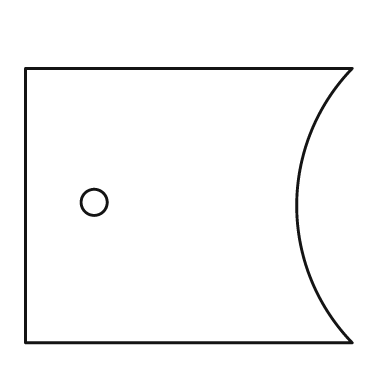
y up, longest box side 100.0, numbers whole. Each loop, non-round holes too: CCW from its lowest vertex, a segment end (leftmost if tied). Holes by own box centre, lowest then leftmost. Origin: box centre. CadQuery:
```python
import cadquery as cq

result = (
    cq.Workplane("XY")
    .moveTo(-50.0, -42.0)
    .lineTo(50.0, -42.0)
    .threePointArc((33.0, 0.0), (50.0, 42.0))
    .lineTo(-50.0, 42.0)
    .close()
    .moveTo(-29.0, 1.0)
    .circle(4.0)
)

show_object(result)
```